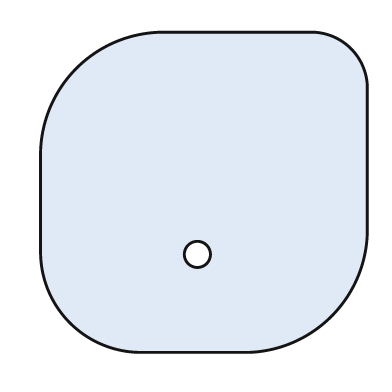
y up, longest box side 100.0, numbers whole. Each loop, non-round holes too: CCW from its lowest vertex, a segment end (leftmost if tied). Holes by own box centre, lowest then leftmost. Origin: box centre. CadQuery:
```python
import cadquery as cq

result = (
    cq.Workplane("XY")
    .moveTo(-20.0, -49.0)
    .lineTo(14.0, -49.0)
    .threePointArc((39.0, -38.0), (50.0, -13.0))
    .lineTo(50.0, 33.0)
    .threePointArc((45.0, 44.0), (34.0, 49.0))
    .lineTo(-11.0, 49.0)
    .threePointArc((-39.0, 38.0), (-50.0, 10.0))
    .lineTo(-50.0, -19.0)
    .threePointArc((-41.0, -40.0), (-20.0, -49.0))
    .close()
    .moveTo(-2.0, -19.0)
    .circle(4.0)
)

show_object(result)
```